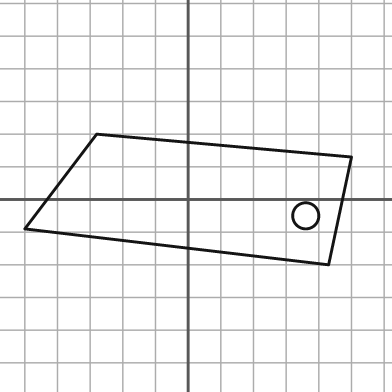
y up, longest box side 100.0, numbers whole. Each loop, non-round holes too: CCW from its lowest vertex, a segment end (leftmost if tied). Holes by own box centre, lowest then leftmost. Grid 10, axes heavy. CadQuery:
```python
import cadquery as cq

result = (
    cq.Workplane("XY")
    .moveTo(43.0, -20.0)
    .lineTo(50.0, 13.0)
    .lineTo(-28.0, 20.0)
    .lineTo(-50.0, -9.0)
    .close()
    .moveTo(36.0, -5.0)
    .circle(4.0)
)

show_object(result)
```